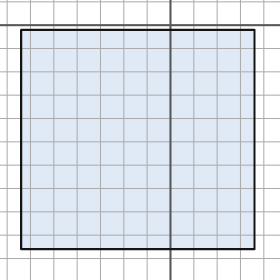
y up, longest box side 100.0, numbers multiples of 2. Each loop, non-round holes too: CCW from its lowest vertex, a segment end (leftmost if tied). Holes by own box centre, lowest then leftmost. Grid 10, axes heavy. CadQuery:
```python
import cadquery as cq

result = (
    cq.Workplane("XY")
    .moveTo(-64.0, -96.0)
    .lineTo(36.0, -96.0)
    .lineTo(36.0, -2.0)
    .lineTo(-64.0, -2.0)
    .close()
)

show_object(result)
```